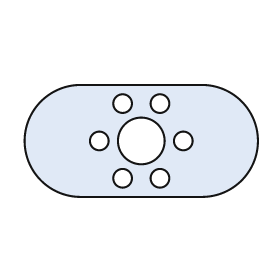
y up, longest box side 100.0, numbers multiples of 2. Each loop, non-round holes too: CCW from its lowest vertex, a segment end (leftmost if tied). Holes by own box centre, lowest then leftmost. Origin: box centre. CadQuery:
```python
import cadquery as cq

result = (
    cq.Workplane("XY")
    .moveTo(-26.0, -24.0)
    .lineTo(26.0, -24.0)
    .threePointArc((50.0, 0.0), (26.0, 24.0))
    .lineTo(-26.0, 24.0)
    .threePointArc((-50.0, 0.0), (-26.0, -24.0))
    .close()
    .moveTo(-8.0, -16.0)
    .circle(4.0)
    .moveTo(8.0, -16.0)
    .circle(4.0)
    .moveTo(-18.0, 0.0)
    .circle(4.0)
    .moveTo(0.0, 0.0)
    .circle(10.0)
    .moveTo(18.0, 0.0)
    .circle(4.0)
    .moveTo(-8.0, 16.0)
    .circle(4.0)
    .moveTo(8.0, 16.0)
    .circle(4.0)
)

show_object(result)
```